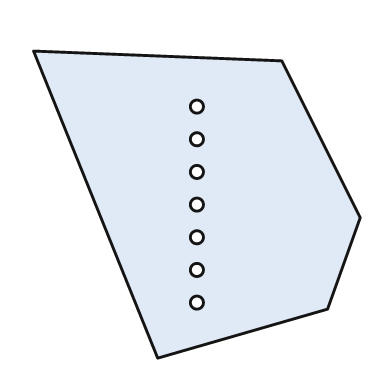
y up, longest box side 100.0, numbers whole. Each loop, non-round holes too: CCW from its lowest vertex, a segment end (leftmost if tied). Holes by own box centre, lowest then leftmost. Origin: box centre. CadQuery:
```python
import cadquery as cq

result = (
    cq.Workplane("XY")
    .moveTo(-12.0, -47.0)
    .lineTo(40.0, -32.0)
    .lineTo(50.0, -4.0)
    .lineTo(26.0, 44.0)
    .lineTo(-50.0, 47.0)
    .close()
    .moveTo(0.0, -30.0)
    .circle(2.0)
    .moveTo(0.0, -20.0)
    .circle(2.0)
    .moveTo(0.0, -10.0)
    .circle(2.0)
    .moveTo(0.0, 0.0)
    .circle(2.0)
    .moveTo(0.0, 10.0)
    .circle(2.0)
    .moveTo(0.0, 20.0)
    .circle(2.0)
    .moveTo(0.0, 30.0)
    .circle(2.0)
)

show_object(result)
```